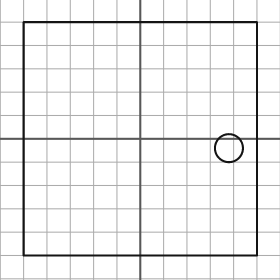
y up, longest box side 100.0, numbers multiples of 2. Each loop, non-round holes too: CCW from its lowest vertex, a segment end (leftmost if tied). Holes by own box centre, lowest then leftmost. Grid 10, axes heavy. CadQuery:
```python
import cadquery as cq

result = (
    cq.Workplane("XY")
    .moveTo(-50.0, -50.0)
    .lineTo(50.0, -50.0)
    .lineTo(50.0, 50.0)
    .lineTo(-50.0, 50.0)
    .close()
    .moveTo(38.0, -4.0)
    .circle(6.0)
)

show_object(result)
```